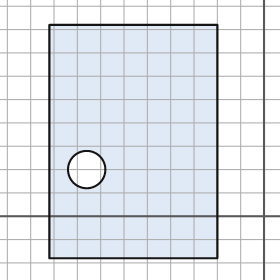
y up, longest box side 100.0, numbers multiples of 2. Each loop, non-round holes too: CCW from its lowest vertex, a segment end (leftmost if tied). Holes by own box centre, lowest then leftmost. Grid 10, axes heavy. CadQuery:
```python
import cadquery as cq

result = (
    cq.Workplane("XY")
    .moveTo(-92.0, -18.0)
    .lineTo(-20.0, -18.0)
    .lineTo(-20.0, 82.0)
    .lineTo(-92.0, 82.0)
    .close()
    .moveTo(-76.0, 20.0)
    .circle(8.0)
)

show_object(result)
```